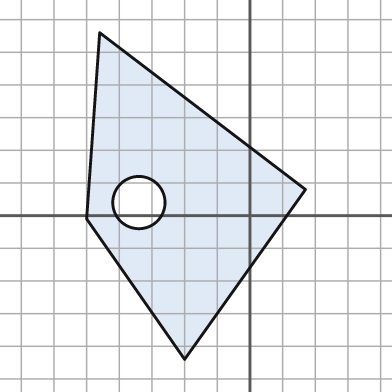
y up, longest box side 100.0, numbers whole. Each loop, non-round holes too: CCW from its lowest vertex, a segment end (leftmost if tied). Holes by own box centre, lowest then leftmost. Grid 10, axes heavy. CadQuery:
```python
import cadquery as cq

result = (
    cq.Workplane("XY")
    .moveTo(-20.0, -44.0)
    .lineTo(17.0, 8.0)
    .lineTo(-46.0, 56.0)
    .lineTo(-50.0, -1.0)
    .close()
    .moveTo(-34.0, 4.0)
    .circle(8.0)
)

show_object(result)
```